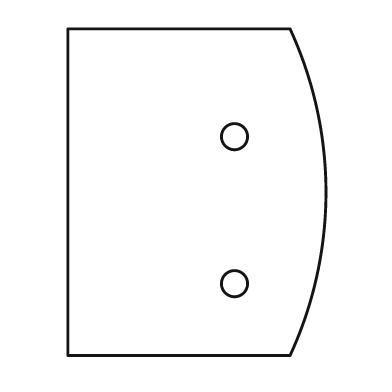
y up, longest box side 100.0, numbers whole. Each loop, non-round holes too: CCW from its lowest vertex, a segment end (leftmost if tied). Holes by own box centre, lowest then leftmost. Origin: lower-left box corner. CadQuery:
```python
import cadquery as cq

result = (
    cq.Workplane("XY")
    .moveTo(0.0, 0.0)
    .lineTo(68.0, 0.0)
    .threePointArc((79.0, 50.0), (68.0, 100.0))
    .lineTo(0.0, 100.0)
    .close()
    .moveTo(51.0, 22.0)
    .circle(4.0)
    .moveTo(51.0, 67.0)
    .circle(4.0)
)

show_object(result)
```